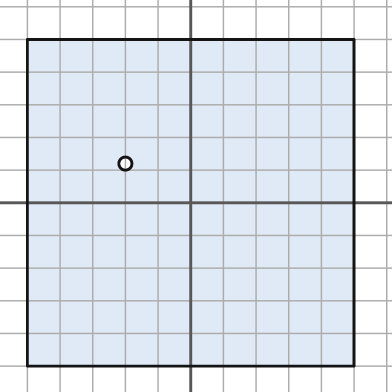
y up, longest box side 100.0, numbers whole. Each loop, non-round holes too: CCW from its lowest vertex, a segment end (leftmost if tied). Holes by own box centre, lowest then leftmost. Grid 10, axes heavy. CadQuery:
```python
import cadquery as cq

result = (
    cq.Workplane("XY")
    .moveTo(-50.0, -50.0)
    .lineTo(50.0, -50.0)
    .lineTo(50.0, 50.0)
    .lineTo(-50.0, 50.0)
    .close()
    .moveTo(-20.0, 12.0)
    .circle(2.0)
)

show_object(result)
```